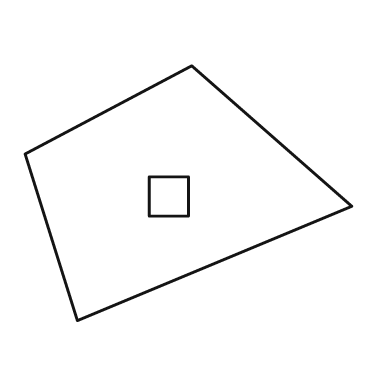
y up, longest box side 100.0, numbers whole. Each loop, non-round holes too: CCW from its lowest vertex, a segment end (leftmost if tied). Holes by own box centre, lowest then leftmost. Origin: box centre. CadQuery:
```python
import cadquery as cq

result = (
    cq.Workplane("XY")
    .moveTo(-34.0, -39.0)
    .lineTo(50.0, -4.0)
    .lineTo(1.0, 39.0)
    .lineTo(-50.0, 12.0)
    .close()
    .moveTo(-12.0, -7.0)
    .lineTo(0.0, -7.0)
    .lineTo(0.0, 5.0)
    .lineTo(-12.0, 5.0)
    .close()
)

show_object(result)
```